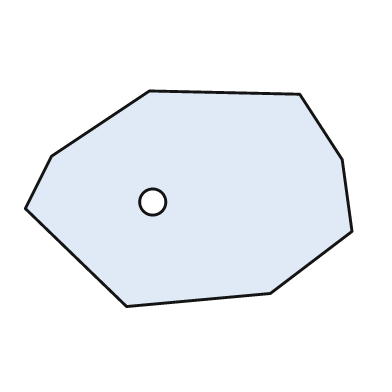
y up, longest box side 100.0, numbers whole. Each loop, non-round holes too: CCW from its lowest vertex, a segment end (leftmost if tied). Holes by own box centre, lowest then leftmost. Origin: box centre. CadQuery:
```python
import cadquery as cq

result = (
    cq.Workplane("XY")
    .moveTo(-19.0, -33.0)
    .lineTo(25.0, -29.0)
    .lineTo(50.0, -10.0)
    .lineTo(47.0, 12.0)
    .lineTo(34.0, 32.0)
    .lineTo(-12.0, 33.0)
    .lineTo(-42.0, 13.0)
    .lineTo(-50.0, -3.0)
    .close()
    .moveTo(-11.0, -1.0)
    .circle(4.0)
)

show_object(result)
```